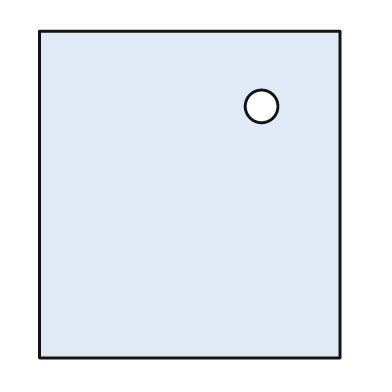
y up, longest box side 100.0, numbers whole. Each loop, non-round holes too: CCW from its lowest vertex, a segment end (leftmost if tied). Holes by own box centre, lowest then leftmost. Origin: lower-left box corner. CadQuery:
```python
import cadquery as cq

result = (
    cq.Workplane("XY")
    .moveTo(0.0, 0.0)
    .lineTo(92.0, 0.0)
    .lineTo(92.0, 100.0)
    .lineTo(0.0, 100.0)
    .close()
    .moveTo(68.0, 77.0)
    .circle(5.0)
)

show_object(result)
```